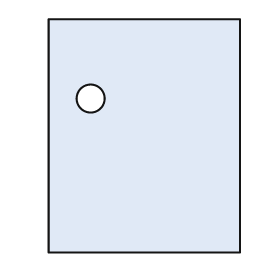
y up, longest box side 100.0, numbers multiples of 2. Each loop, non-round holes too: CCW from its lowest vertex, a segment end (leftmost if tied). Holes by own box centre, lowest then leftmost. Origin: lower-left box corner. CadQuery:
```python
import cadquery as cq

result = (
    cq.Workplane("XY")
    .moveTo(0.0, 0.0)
    .lineTo(82.0, 0.0)
    .lineTo(82.0, 100.0)
    .lineTo(0.0, 100.0)
    .close()
    .moveTo(18.0, 66.0)
    .circle(6.0)
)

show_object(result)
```